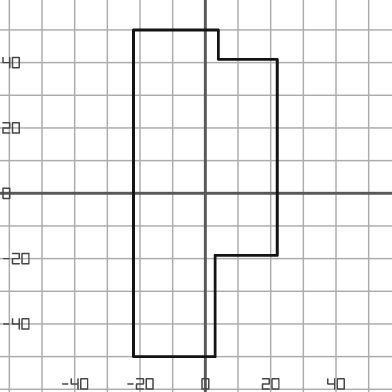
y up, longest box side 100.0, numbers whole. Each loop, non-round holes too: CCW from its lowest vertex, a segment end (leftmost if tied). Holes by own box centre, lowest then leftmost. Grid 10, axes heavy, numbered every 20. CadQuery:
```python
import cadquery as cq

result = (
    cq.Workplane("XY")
    .moveTo(-22.0, -50.0)
    .lineTo(3.0, -50.0)
    .lineTo(3.0, -19.0)
    .lineTo(22.0, -19.0)
    .lineTo(22.0, 41.0)
    .lineTo(4.0, 41.0)
    .lineTo(4.0, 50.0)
    .lineTo(-22.0, 50.0)
    .close()
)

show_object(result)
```